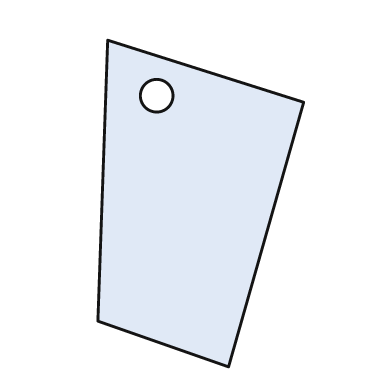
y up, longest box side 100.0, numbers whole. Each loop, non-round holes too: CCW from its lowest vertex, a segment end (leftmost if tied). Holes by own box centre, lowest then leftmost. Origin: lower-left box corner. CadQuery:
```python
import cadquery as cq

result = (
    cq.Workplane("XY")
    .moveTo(40.0, 0.0)
    .lineTo(63.0, 81.0)
    .lineTo(3.0, 100.0)
    .lineTo(0.0, 14.0)
    .close()
    .moveTo(18.0, 83.0)
    .circle(5.0)
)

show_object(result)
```